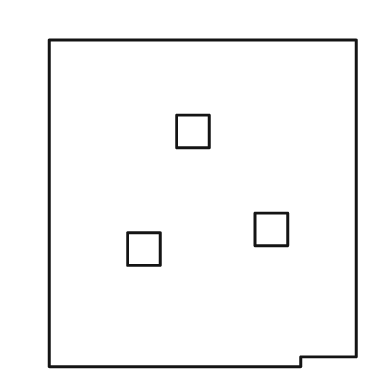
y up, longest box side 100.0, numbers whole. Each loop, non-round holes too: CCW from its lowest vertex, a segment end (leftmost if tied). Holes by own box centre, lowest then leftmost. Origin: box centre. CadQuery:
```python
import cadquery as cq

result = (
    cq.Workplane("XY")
    .moveTo(-47.0, -50.0)
    .lineTo(30.0, -50.0)
    .lineTo(30.0, -47.0)
    .lineTo(47.0, -47.0)
    .lineTo(47.0, 50.0)
    .lineTo(-47.0, 50.0)
    .close()
    .moveTo(-23.0, -19.0)
    .lineTo(-13.0, -19.0)
    .lineTo(-13.0, -9.0)
    .lineTo(-23.0, -9.0)
    .close()
    .moveTo(16.0, -13.0)
    .lineTo(26.0, -13.0)
    .lineTo(26.0, -3.0)
    .lineTo(16.0, -3.0)
    .close()
    .moveTo(-8.0, 17.0)
    .lineTo(2.0, 17.0)
    .lineTo(2.0, 27.0)
    .lineTo(-8.0, 27.0)
    .close()
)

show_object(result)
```